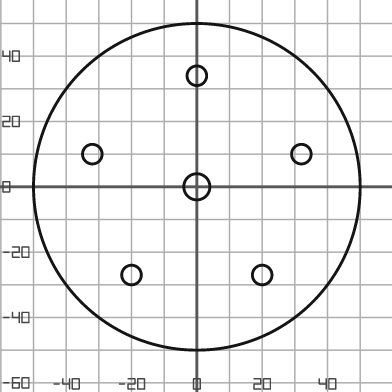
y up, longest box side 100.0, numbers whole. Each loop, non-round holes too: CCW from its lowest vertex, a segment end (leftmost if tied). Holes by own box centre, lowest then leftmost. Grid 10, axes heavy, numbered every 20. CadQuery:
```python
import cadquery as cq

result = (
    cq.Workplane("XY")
    .moveTo(0.0, 0.0)
    .circle(50.0)
    .moveTo(-20.0, -27.0)
    .circle(3.0)
    .moveTo(20.0, -27.0)
    .circle(3.0)
    .moveTo(0.0, 0.0)
    .circle(4.0)
    .moveTo(-32.0, 10.0)
    .circle(3.0)
    .moveTo(32.0, 10.0)
    .circle(3.0)
    .moveTo(0.0, 34.0)
    .circle(3.0)
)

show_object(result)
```